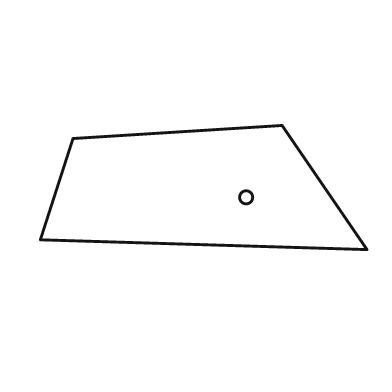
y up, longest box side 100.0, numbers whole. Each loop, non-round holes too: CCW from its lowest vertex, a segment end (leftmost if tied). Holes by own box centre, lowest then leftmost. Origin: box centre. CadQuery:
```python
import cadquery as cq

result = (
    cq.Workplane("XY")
    .moveTo(50.0, -19.0)
    .lineTo(24.0, 19.0)
    .lineTo(-40.0, 15.0)
    .lineTo(-50.0, -16.0)
    .close()
    .moveTo(13.0, -3.0)
    .circle(2.0)
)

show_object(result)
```